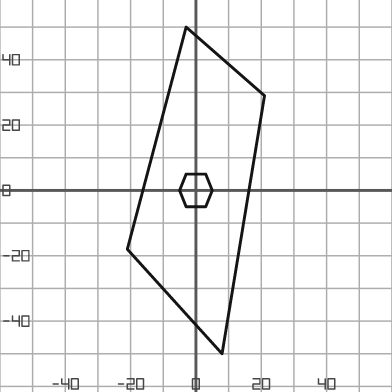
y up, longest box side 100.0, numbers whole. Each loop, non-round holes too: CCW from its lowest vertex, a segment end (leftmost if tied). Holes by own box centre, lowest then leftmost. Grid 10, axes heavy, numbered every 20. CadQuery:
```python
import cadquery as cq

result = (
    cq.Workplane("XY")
    .moveTo(8.0, -50.0)
    .lineTo(21.0, 29.0)
    .lineTo(-3.0, 50.0)
    .lineTo(-21.0, -18.0)
    .close()
    .moveTo(-3.0, -5.0)
    .lineTo(3.0, -5.0)
    .lineTo(5.0, 0.0)
    .lineTo(3.0, 5.0)
    .lineTo(-3.0, 5.0)
    .lineTo(-5.0, 0.0)
    .close()
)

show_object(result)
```